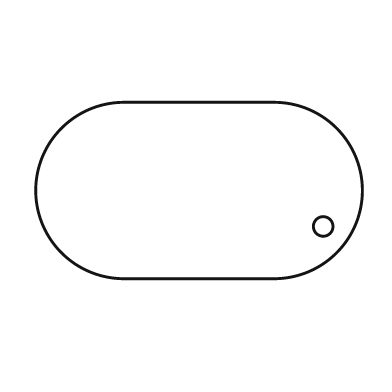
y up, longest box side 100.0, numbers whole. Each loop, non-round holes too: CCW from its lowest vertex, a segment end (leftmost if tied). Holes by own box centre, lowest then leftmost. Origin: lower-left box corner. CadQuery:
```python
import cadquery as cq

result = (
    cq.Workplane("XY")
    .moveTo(27.0, 0.0)
    .lineTo(73.0, 0.0)
    .threePointArc((100.0, 27.0), (73.0, 54.0))
    .lineTo(27.0, 54.0)
    .threePointArc((0.0, 27.0), (27.0, 0.0))
    .close()
    .moveTo(88.0, 16.0)
    .circle(3.0)
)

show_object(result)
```